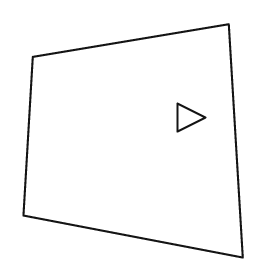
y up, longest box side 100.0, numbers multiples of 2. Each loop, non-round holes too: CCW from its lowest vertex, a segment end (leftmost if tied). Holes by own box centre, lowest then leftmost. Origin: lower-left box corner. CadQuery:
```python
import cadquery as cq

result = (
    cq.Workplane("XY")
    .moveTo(94.0, 0.0)
    .lineTo(88.0, 100.0)
    .lineTo(4.0, 86.0)
    .lineTo(0.0, 18.0)
    .close()
    .moveTo(66.0, 54.0)
    .lineTo(78.0, 60.0)
    .lineTo(66.0, 66.0)
    .close()
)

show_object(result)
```